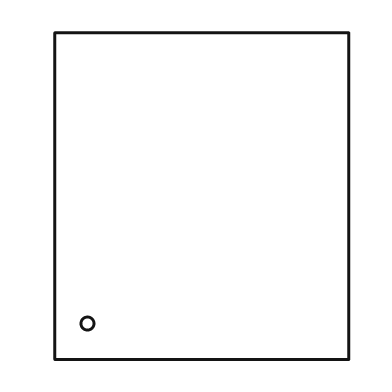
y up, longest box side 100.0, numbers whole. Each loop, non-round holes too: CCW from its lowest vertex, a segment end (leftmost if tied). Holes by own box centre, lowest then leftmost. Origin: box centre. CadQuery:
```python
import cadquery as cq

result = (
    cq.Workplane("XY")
    .moveTo(-45.0, -50.0)
    .lineTo(45.0, -50.0)
    .lineTo(45.0, 50.0)
    .lineTo(-45.0, 50.0)
    .close()
    .moveTo(-35.0, -39.0)
    .circle(2.0)
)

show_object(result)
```